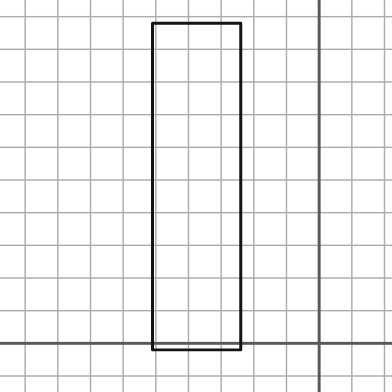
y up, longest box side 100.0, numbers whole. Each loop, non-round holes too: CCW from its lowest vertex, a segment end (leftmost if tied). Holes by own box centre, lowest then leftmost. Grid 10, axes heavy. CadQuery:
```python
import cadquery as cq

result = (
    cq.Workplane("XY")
    .moveTo(-51.0, -2.0)
    .lineTo(-24.0, -2.0)
    .lineTo(-24.0, 98.0)
    .lineTo(-51.0, 98.0)
    .close()
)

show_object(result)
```